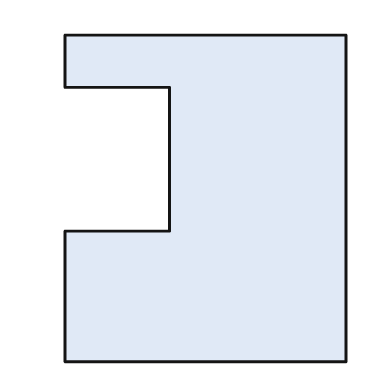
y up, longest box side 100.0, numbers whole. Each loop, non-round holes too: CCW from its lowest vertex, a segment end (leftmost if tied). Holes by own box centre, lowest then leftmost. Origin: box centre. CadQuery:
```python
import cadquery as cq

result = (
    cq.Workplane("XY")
    .moveTo(-43.0, -50.0)
    .lineTo(43.0, -50.0)
    .lineTo(43.0, 50.0)
    .lineTo(-43.0, 50.0)
    .lineTo(-43.0, 34.0)
    .lineTo(-11.0, 34.0)
    .lineTo(-11.0, -10.0)
    .lineTo(-43.0, -10.0)
    .close()
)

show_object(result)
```